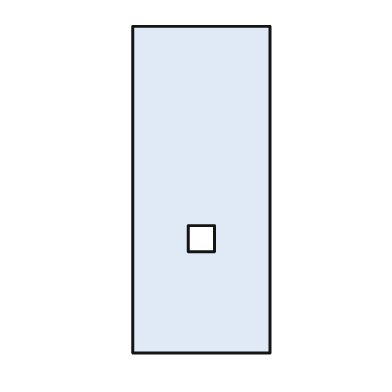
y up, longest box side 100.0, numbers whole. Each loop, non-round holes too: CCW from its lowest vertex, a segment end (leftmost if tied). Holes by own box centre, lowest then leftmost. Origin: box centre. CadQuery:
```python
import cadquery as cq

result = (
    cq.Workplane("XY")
    .moveTo(-21.0, -50.0)
    .lineTo(21.0, -50.0)
    .lineTo(21.0, 50.0)
    .lineTo(-21.0, 50.0)
    .close()
    .moveTo(-4.0, -19.0)
    .lineTo(4.0, -19.0)
    .lineTo(4.0, -11.0)
    .lineTo(-4.0, -11.0)
    .close()
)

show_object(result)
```